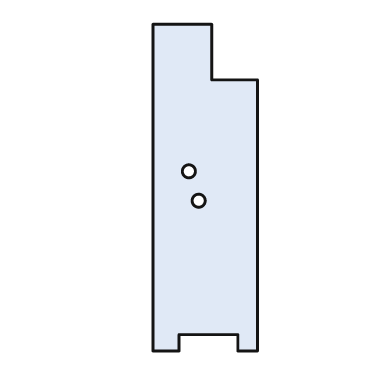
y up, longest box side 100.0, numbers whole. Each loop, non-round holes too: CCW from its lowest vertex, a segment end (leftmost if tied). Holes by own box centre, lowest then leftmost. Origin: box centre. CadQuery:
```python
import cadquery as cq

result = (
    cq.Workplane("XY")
    .moveTo(-16.0, -50.0)
    .lineTo(-8.0, -50.0)
    .lineTo(-8.0, -45.0)
    .lineTo(10.0, -45.0)
    .lineTo(10.0, -50.0)
    .lineTo(16.0, -50.0)
    .lineTo(16.0, 33.0)
    .lineTo(2.0, 33.0)
    .lineTo(2.0, 50.0)
    .lineTo(-16.0, 50.0)
    .close()
    .moveTo(-2.0, -4.0)
    .circle(2.0)
    .moveTo(-5.0, 5.0)
    .circle(2.0)
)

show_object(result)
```